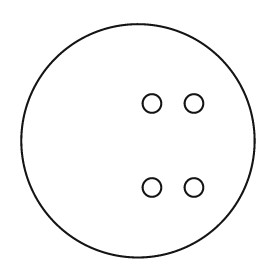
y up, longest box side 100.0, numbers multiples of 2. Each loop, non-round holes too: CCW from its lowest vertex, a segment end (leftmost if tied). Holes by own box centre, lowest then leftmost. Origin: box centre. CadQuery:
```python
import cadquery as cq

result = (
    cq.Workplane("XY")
    .moveTo(0.0, 0.0)
    .circle(50.0)
    .moveTo(6.0, -20.0)
    .circle(4.0)
    .moveTo(24.0, -20.0)
    .circle(4.0)
    .moveTo(6.0, 16.0)
    .circle(4.0)
    .moveTo(24.0, 16.0)
    .circle(4.0)
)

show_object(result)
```